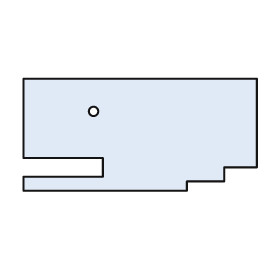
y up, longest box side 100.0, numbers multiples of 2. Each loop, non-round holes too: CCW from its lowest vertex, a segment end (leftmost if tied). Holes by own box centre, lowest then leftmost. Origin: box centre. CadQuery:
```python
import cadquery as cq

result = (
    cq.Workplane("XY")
    .moveTo(-50.0, -24.0)
    .lineTo(20.0, -24.0)
    .lineTo(20.0, -20.0)
    .lineTo(36.0, -20.0)
    .lineTo(36.0, -14.0)
    .lineTo(50.0, -14.0)
    .lineTo(50.0, 24.0)
    .lineTo(-50.0, 24.0)
    .lineTo(-50.0, -10.0)
    .lineTo(-16.0, -10.0)
    .lineTo(-16.0, -18.0)
    .lineTo(-50.0, -18.0)
    .close()
    .moveTo(-20.0, 10.0)
    .circle(2.0)
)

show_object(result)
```